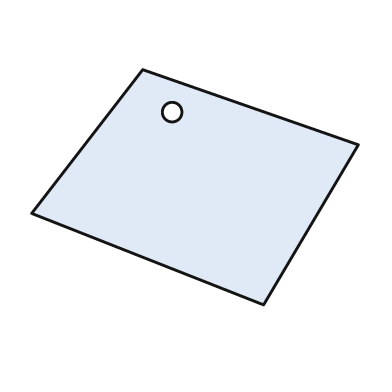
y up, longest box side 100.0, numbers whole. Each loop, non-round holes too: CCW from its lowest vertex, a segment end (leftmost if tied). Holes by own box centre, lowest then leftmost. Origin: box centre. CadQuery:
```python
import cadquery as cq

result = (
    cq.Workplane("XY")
    .moveTo(21.0, -36.0)
    .lineTo(50.0, 13.0)
    .lineTo(-16.0, 36.0)
    .lineTo(-50.0, -8.0)
    .close()
    .moveTo(-7.0, 23.0)
    .circle(3.0)
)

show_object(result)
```